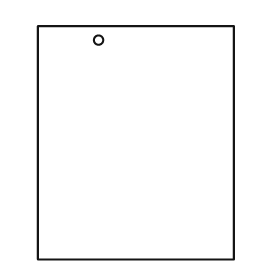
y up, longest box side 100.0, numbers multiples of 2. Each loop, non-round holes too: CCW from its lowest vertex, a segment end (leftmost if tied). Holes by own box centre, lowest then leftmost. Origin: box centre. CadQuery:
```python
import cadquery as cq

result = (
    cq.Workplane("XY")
    .moveTo(-42.0, -50.0)
    .lineTo(42.0, -50.0)
    .lineTo(42.0, 50.0)
    .lineTo(-42.0, 50.0)
    .close()
    .moveTo(-16.0, 44.0)
    .circle(2.0)
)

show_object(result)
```